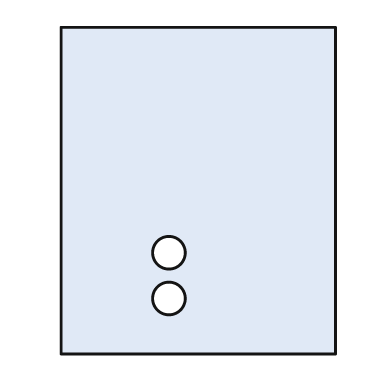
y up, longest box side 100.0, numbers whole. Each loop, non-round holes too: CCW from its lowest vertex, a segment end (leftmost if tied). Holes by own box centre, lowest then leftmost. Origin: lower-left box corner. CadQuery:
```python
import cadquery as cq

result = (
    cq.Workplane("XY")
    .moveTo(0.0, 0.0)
    .lineTo(84.0, 0.0)
    .lineTo(84.0, 100.0)
    .lineTo(0.0, 100.0)
    .close()
    .moveTo(33.0, 17.0)
    .circle(5.0)
    .moveTo(33.0, 31.0)
    .circle(5.0)
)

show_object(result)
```